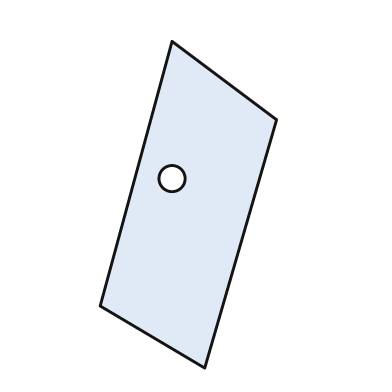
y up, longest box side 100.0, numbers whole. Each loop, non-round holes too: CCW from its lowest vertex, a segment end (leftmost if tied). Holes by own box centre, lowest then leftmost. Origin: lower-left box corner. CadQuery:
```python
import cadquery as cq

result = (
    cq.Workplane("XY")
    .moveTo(32.0, 0.0)
    .lineTo(54.0, 76.0)
    .lineTo(22.0, 100.0)
    .lineTo(0.0, 19.0)
    .close()
    .moveTo(22.0, 58.0)
    .circle(4.0)
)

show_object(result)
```